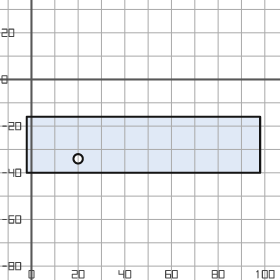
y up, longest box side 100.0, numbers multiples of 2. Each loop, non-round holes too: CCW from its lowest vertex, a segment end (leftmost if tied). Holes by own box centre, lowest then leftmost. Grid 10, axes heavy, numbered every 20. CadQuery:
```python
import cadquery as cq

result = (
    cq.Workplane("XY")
    .moveTo(-2.0, -40.0)
    .lineTo(98.0, -40.0)
    .lineTo(98.0, -16.0)
    .lineTo(-2.0, -16.0)
    .close()
    .moveTo(20.0, -34.0)
    .circle(2.0)
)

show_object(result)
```